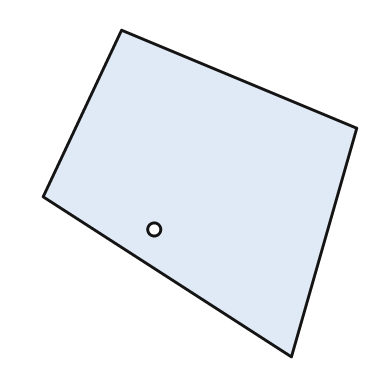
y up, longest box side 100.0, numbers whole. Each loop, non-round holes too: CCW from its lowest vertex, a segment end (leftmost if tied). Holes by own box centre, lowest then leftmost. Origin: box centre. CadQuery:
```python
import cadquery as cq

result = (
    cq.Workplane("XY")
    .moveTo(28.0, -50.0)
    .lineTo(48.0, 20.0)
    .lineTo(-24.0, 50.0)
    .lineTo(-48.0, -1.0)
    .close()
    .moveTo(-14.0, -11.0)
    .circle(2.0)
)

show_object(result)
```